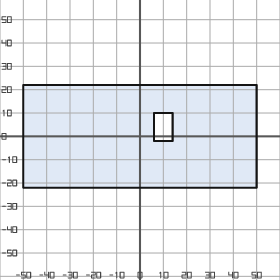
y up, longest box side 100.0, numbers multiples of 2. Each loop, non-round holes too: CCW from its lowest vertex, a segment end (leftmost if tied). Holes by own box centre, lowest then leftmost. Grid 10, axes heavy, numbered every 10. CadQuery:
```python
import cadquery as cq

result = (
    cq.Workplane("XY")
    .moveTo(-50.0, -22.0)
    .lineTo(50.0, -22.0)
    .lineTo(50.0, 22.0)
    .lineTo(-50.0, 22.0)
    .close()
    .moveTo(6.0, -2.0)
    .lineTo(14.0, -2.0)
    .lineTo(14.0, 10.0)
    .lineTo(6.0, 10.0)
    .close()
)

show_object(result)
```